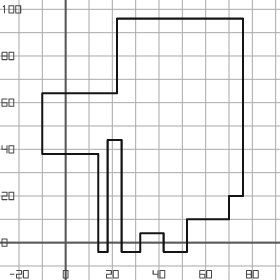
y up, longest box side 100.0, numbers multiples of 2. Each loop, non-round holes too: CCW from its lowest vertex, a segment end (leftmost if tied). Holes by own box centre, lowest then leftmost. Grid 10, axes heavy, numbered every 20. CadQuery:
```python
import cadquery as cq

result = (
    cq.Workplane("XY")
    .moveTo(14.0, -4.0)
    .lineTo(18.0, -4.0)
    .lineTo(18.0, 44.0)
    .lineTo(24.0, 44.0)
    .lineTo(24.0, -4.0)
    .lineTo(32.0, -4.0)
    .lineTo(32.0, 4.0)
    .lineTo(42.0, 4.0)
    .lineTo(42.0, -4.0)
    .lineTo(52.0, -4.0)
    .lineTo(52.0, 10.0)
    .lineTo(70.0, 10.0)
    .lineTo(70.0, 20.0)
    .lineTo(76.0, 20.0)
    .lineTo(76.0, 96.0)
    .lineTo(22.0, 96.0)
    .lineTo(22.0, 64.0)
    .lineTo(-10.0, 64.0)
    .lineTo(-10.0, 38.0)
    .lineTo(14.0, 38.0)
    .close()
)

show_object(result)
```